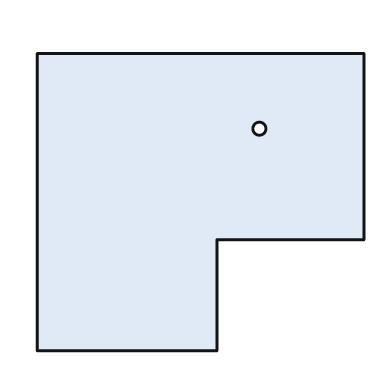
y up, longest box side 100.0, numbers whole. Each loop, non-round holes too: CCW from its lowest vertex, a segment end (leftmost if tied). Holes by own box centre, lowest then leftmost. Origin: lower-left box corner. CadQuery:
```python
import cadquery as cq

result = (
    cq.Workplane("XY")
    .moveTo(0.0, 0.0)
    .lineTo(55.0, 0.0)
    .lineTo(55.0, 34.0)
    .lineTo(100.0, 34.0)
    .lineTo(100.0, 91.0)
    .lineTo(0.0, 91.0)
    .close()
    .moveTo(68.0, 68.0)
    .circle(2.0)
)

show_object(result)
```